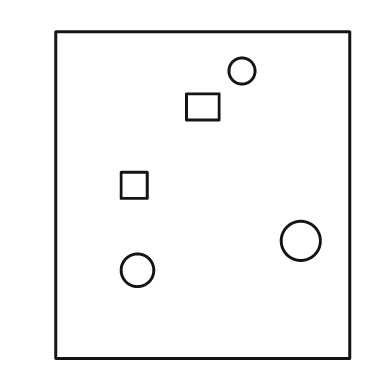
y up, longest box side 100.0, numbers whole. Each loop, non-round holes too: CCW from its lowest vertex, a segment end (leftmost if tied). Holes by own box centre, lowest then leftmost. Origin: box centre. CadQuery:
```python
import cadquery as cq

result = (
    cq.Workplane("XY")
    .moveTo(-45.0, -50.0)
    .lineTo(45.0, -50.0)
    .lineTo(45.0, 50.0)
    .lineTo(-45.0, 50.0)
    .close()
    .moveTo(-20.0, -23.0)
    .circle(5.0)
    .moveTo(30.0, -14.0)
    .circle(6.0)
    .moveTo(-25.0, -1.0)
    .lineTo(-17.0, -1.0)
    .lineTo(-17.0, 7.0)
    .lineTo(-25.0, 7.0)
    .close()
    .moveTo(-5.0, 23.0)
    .lineTo(5.0, 23.0)
    .lineTo(5.0, 31.0)
    .lineTo(-5.0, 31.0)
    .close()
    .moveTo(12.0, 38.0)
    .circle(4.0)
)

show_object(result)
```